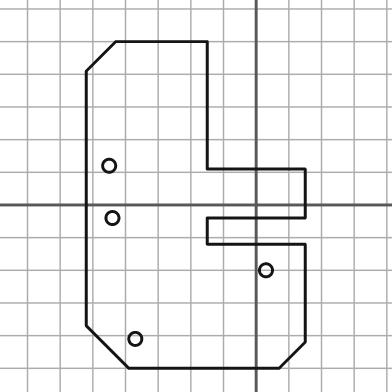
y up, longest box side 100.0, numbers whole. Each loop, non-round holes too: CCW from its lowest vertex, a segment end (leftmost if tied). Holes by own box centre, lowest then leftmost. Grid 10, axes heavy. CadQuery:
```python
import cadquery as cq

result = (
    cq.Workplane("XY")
    .moveTo(-39.0, -50.0)
    .lineTo(7.0, -50.0)
    .lineTo(15.0, -42.0)
    .lineTo(15.0, -12.0)
    .lineTo(-15.0, -12.0)
    .lineTo(-15.0, -4.0)
    .lineTo(15.0, -4.0)
    .lineTo(15.0, 11.0)
    .lineTo(-15.0, 11.0)
    .lineTo(-15.0, 50.0)
    .lineTo(-43.0, 50.0)
    .lineTo(-52.0, 41.0)
    .lineTo(-52.0, -37.0)
    .close()
    .moveTo(-37.0, -41.0)
    .circle(2.0)
    .moveTo(3.0, -20.0)
    .circle(2.0)
    .moveTo(-44.0, -4.0)
    .circle(2.0)
    .moveTo(-45.0, 12.0)
    .circle(2.0)
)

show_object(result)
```